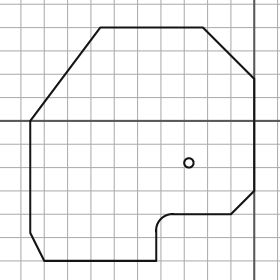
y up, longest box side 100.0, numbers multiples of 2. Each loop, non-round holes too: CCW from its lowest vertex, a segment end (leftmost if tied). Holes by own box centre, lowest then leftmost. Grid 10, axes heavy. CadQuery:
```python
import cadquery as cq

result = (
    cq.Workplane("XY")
    .moveTo(-90.0, -60.0)
    .lineTo(-42.0, -60.0)
    .lineTo(-42.0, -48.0)
    .threePointArc((-40.0, -42.0), (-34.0, -40.0))
    .lineTo(-10.0, -40.0)
    .lineTo(0.0, -30.0)
    .lineTo(0.0, 18.0)
    .lineTo(-22.0, 40.0)
    .lineTo(-66.0, 40.0)
    .lineTo(-96.0, 0.0)
    .lineTo(-96.0, -48.0)
    .close()
    .moveTo(-28.0, -18.0)
    .circle(2.0)
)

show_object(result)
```